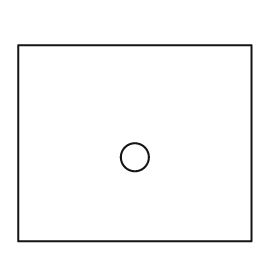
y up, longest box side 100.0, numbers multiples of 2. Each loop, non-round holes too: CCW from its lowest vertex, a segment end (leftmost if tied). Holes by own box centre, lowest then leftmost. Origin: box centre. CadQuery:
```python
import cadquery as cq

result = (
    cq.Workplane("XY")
    .moveTo(-50.0, -42.0)
    .lineTo(50.0, -42.0)
    .lineTo(50.0, 42.0)
    .lineTo(-50.0, 42.0)
    .close()
    .moveTo(0.0, -6.0)
    .circle(6.0)
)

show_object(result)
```